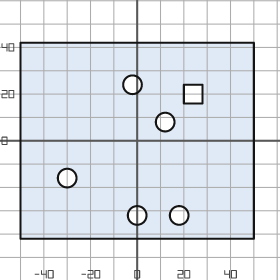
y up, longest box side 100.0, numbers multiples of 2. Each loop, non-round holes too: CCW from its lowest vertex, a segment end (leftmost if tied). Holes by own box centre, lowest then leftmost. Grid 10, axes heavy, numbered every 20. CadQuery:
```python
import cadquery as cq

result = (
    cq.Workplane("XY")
    .moveTo(-50.0, -42.0)
    .lineTo(50.0, -42.0)
    .lineTo(50.0, 42.0)
    .lineTo(-50.0, 42.0)
    .close()
    .moveTo(0.0, -32.0)
    .circle(4.0)
    .moveTo(18.0, -32.0)
    .circle(4.0)
    .moveTo(-30.0, -16.0)
    .circle(4.0)
    .moveTo(12.0, 8.0)
    .circle(4.0)
    .moveTo(20.0, 16.0)
    .lineTo(28.0, 16.0)
    .lineTo(28.0, 24.0)
    .lineTo(20.0, 24.0)
    .close()
    .moveTo(-2.0, 24.0)
    .circle(4.0)
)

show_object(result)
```